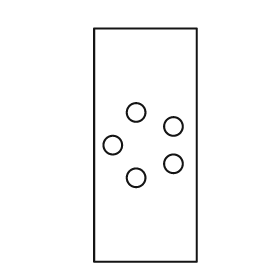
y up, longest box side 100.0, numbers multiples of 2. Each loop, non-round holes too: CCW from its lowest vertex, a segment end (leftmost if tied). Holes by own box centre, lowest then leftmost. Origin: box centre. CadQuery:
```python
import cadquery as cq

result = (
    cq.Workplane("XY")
    .moveTo(-22.0, -50.0)
    .lineTo(22.0, -50.0)
    .lineTo(22.0, 50.0)
    .lineTo(-22.0, 50.0)
    .close()
    .moveTo(-4.0, -14.0)
    .circle(4.0)
    .moveTo(12.0, -8.0)
    .circle(4.0)
    .moveTo(-14.0, 0.0)
    .circle(4.0)
    .moveTo(12.0, 8.0)
    .circle(4.0)
    .moveTo(-4.0, 14.0)
    .circle(4.0)
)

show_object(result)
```